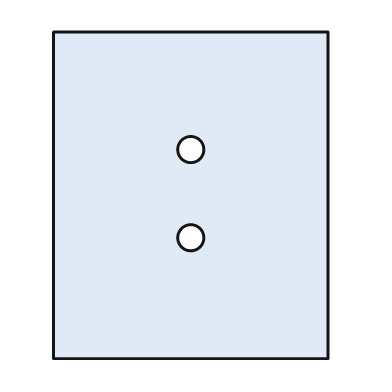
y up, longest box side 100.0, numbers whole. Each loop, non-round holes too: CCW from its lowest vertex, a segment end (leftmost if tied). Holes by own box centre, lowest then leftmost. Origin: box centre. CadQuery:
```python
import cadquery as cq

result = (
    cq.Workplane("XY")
    .moveTo(-42.0, -50.0)
    .lineTo(42.0, -50.0)
    .lineTo(42.0, 50.0)
    .lineTo(-42.0, 50.0)
    .close()
    .moveTo(0.0, -13.0)
    .circle(4.0)
    .moveTo(0.0, 14.0)
    .circle(4.0)
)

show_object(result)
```